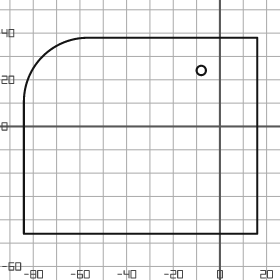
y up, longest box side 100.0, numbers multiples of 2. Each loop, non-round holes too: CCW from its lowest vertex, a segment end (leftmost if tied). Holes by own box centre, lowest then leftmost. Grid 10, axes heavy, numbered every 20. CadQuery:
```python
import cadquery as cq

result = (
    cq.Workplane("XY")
    .moveTo(-84.0, -46.0)
    .lineTo(16.0, -46.0)
    .lineTo(16.0, 38.0)
    .lineTo(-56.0, 38.0)
    .threePointArc((-76.0, 30.0), (-84.0, 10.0))
    .close()
    .moveTo(-8.0, 24.0)
    .circle(2.0)
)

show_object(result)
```